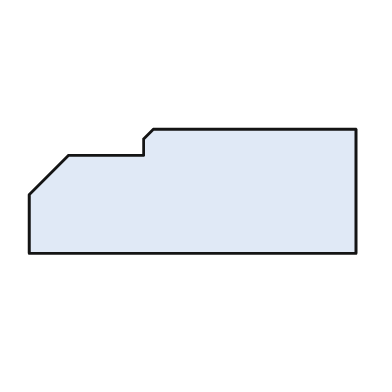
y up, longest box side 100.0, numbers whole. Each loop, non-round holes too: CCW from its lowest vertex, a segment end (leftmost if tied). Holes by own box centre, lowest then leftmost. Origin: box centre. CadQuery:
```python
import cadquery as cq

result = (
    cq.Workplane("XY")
    .moveTo(-50.0, -19.0)
    .lineTo(50.0, -19.0)
    .lineTo(50.0, 19.0)
    .lineTo(-12.0, 19.0)
    .lineTo(-15.0, 16.0)
    .lineTo(-15.0, 11.0)
    .lineTo(-38.0, 11.0)
    .lineTo(-50.0, -1.0)
    .close()
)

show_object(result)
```